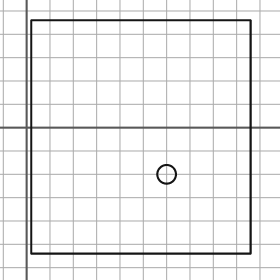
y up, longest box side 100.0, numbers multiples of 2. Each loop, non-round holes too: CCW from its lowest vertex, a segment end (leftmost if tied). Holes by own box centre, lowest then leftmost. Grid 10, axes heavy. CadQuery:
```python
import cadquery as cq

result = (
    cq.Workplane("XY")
    .moveTo(2.0, -54.0)
    .lineTo(96.0, -54.0)
    .lineTo(96.0, 46.0)
    .lineTo(2.0, 46.0)
    .close()
    .moveTo(60.0, -20.0)
    .circle(4.0)
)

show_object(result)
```